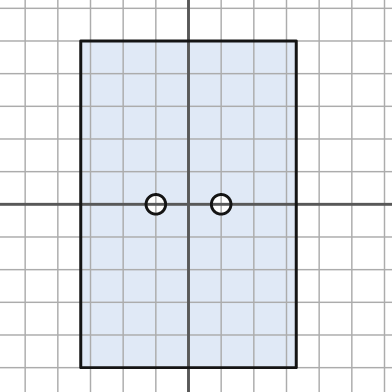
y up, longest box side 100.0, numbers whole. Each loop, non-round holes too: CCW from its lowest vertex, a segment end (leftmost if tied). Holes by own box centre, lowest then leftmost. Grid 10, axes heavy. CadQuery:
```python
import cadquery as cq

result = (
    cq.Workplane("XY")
    .moveTo(-33.0, -50.0)
    .lineTo(33.0, -50.0)
    .lineTo(33.0, 50.0)
    .lineTo(-33.0, 50.0)
    .close()
    .moveTo(-10.0, 0.0)
    .circle(3.0)
    .moveTo(10.0, 0.0)
    .circle(3.0)
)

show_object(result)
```